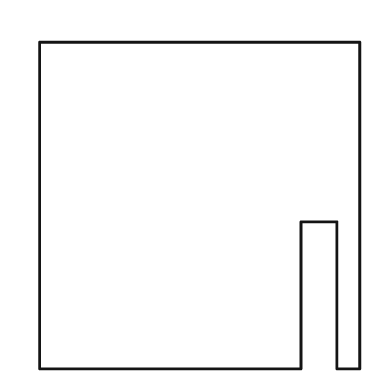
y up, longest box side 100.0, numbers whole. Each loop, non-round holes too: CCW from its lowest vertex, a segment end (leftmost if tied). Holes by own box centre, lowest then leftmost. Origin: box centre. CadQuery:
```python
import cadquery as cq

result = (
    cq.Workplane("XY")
    .moveTo(-49.0, -50.0)
    .lineTo(31.0, -50.0)
    .lineTo(31.0, -5.0)
    .lineTo(42.0, -5.0)
    .lineTo(42.0, -50.0)
    .lineTo(49.0, -50.0)
    .lineTo(49.0, 50.0)
    .lineTo(-49.0, 50.0)
    .close()
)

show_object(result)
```